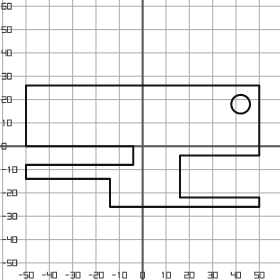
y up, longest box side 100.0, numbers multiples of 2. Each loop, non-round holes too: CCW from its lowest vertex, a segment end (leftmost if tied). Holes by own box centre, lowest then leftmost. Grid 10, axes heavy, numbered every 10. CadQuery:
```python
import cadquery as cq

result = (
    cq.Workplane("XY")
    .moveTo(-14.0, -26.0)
    .lineTo(50.0, -26.0)
    .lineTo(50.0, -22.0)
    .lineTo(16.0, -22.0)
    .lineTo(16.0, -4.0)
    .lineTo(50.0, -4.0)
    .lineTo(50.0, 26.0)
    .lineTo(-50.0, 26.0)
    .lineTo(-50.0, 0.0)
    .lineTo(-4.0, 0.0)
    .lineTo(-4.0, -8.0)
    .lineTo(-50.0, -8.0)
    .lineTo(-50.0, -14.0)
    .lineTo(-14.0, -14.0)
    .close()
    .moveTo(42.0, 18.0)
    .circle(4.0)
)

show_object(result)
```